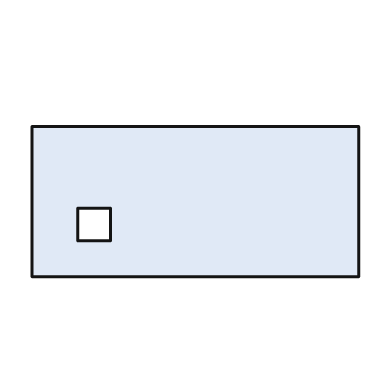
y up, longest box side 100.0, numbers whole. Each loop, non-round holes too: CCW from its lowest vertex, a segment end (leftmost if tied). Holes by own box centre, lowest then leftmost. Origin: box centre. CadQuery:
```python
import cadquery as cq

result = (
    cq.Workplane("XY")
    .moveTo(-50.0, -23.0)
    .lineTo(50.0, -23.0)
    .lineTo(50.0, 23.0)
    .lineTo(-50.0, 23.0)
    .close()
    .moveTo(-36.0, -12.0)
    .lineTo(-26.0, -12.0)
    .lineTo(-26.0, -2.0)
    .lineTo(-36.0, -2.0)
    .close()
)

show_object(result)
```